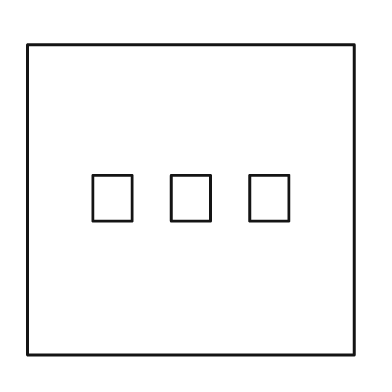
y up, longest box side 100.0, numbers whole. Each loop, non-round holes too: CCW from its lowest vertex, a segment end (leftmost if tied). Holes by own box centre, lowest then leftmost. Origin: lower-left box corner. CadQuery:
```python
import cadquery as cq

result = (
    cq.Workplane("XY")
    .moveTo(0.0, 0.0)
    .lineTo(100.0, 0.0)
    .lineTo(100.0, 95.0)
    .lineTo(0.0, 95.0)
    .close()
    .moveTo(20.0, 41.0)
    .lineTo(32.0, 41.0)
    .lineTo(32.0, 55.0)
    .lineTo(20.0, 55.0)
    .close()
    .moveTo(44.0, 41.0)
    .lineTo(56.0, 41.0)
    .lineTo(56.0, 55.0)
    .lineTo(44.0, 55.0)
    .close()
    .moveTo(68.0, 41.0)
    .lineTo(80.0, 41.0)
    .lineTo(80.0, 55.0)
    .lineTo(68.0, 55.0)
    .close()
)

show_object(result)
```